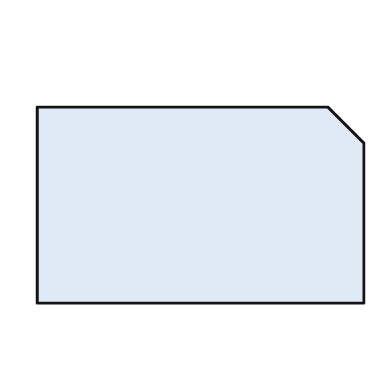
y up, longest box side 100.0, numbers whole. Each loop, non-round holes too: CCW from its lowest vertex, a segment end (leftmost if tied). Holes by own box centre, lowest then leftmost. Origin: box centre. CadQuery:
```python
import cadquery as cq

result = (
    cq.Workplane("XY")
    .moveTo(-50.0, -30.0)
    .lineTo(50.0, -30.0)
    .lineTo(50.0, 19.0)
    .lineTo(39.0, 30.0)
    .lineTo(-50.0, 30.0)
    .close()
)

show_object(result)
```